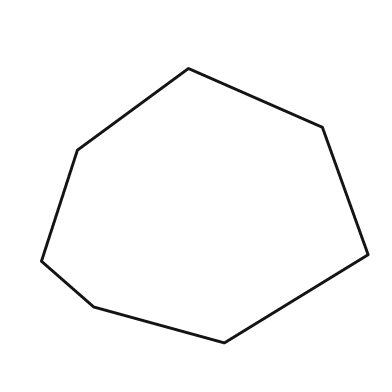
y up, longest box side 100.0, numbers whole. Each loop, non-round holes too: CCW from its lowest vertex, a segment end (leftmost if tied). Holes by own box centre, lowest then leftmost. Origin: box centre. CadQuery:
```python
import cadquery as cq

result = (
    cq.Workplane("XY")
    .moveTo(6.0, -42.0)
    .lineTo(50.0, -15.0)
    .lineTo(36.0, 24.0)
    .lineTo(-5.0, 42.0)
    .lineTo(-39.0, 17.0)
    .lineTo(-50.0, -17.0)
    .lineTo(-34.0, -31.0)
    .close()
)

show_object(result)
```